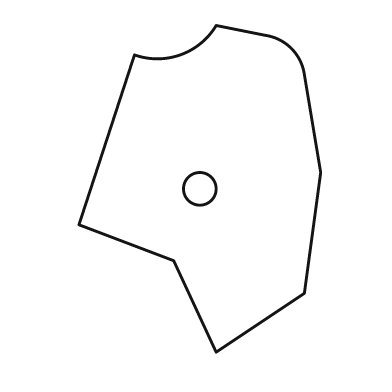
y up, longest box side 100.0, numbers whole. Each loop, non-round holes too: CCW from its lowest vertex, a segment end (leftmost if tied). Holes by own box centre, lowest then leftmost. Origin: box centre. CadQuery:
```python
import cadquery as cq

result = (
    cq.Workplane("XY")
    .moveTo(5.0, -50.0)
    .lineTo(32.0, -32.0)
    .lineTo(37.0, 5.0)
    .lineTo(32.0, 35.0)
    .threePointArc((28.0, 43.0), (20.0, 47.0))
    .lineTo(5.0, 50.0)
    .threePointArc((-6.0, 41.0), (-20.0, 41.0))
    .lineTo(-37.0, -11.0)
    .lineTo(-8.0, -22.0)
    .close()
    .moveTo(0.0, 0.0)
    .circle(5.0)
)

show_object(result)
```